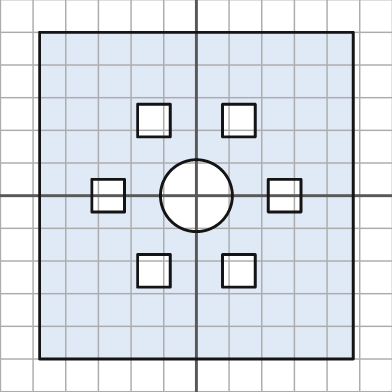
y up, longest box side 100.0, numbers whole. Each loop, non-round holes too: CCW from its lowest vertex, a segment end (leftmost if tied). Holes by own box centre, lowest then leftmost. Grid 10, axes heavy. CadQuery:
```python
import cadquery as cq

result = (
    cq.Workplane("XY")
    .moveTo(-48.0, -50.0)
    .lineTo(48.0, -50.0)
    .lineTo(48.0, 50.0)
    .lineTo(-48.0, 50.0)
    .close()
    .moveTo(-18.0, -28.0)
    .lineTo(-8.0, -28.0)
    .lineTo(-8.0, -18.0)
    .lineTo(-18.0, -18.0)
    .close()
    .moveTo(8.0, -28.0)
    .lineTo(18.0, -28.0)
    .lineTo(18.0, -18.0)
    .lineTo(8.0, -18.0)
    .close()
    .moveTo(-32.0, -5.0)
    .lineTo(-22.0, -5.0)
    .lineTo(-22.0, 5.0)
    .lineTo(-32.0, 5.0)
    .close()
    .moveTo(0.0, 0.0)
    .circle(11.0)
    .moveTo(22.0, -5.0)
    .lineTo(32.0, -5.0)
    .lineTo(32.0, 5.0)
    .lineTo(22.0, 5.0)
    .close()
    .moveTo(-18.0, 18.0)
    .lineTo(-8.0, 18.0)
    .lineTo(-8.0, 28.0)
    .lineTo(-18.0, 28.0)
    .close()
    .moveTo(8.0, 18.0)
    .lineTo(18.0, 18.0)
    .lineTo(18.0, 28.0)
    .lineTo(8.0, 28.0)
    .close()
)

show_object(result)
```